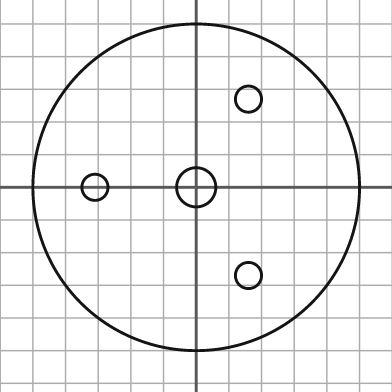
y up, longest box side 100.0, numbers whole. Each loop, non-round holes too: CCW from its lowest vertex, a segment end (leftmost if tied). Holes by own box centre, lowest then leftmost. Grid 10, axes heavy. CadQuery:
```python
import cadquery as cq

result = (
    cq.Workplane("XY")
    .moveTo(0.0, 0.0)
    .circle(50.0)
    .moveTo(16.0, -27.0)
    .circle(4.0)
    .moveTo(-31.0, 0.0)
    .circle(4.0)
    .moveTo(0.0, 0.0)
    .circle(6.0)
    .moveTo(16.0, 27.0)
    .circle(4.0)
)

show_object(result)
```